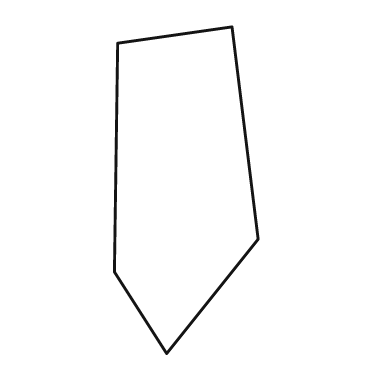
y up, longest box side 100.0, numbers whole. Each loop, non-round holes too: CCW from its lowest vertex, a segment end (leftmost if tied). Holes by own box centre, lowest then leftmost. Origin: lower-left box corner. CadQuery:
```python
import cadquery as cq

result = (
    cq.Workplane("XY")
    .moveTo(16.0, 0.0)
    .lineTo(44.0, 35.0)
    .lineTo(36.0, 100.0)
    .lineTo(1.0, 95.0)
    .lineTo(0.0, 25.0)
    .close()
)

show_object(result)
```